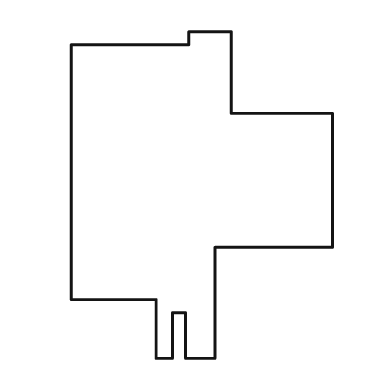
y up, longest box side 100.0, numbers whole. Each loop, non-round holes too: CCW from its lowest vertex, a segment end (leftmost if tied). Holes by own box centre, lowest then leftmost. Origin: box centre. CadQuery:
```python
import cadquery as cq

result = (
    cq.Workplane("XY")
    .moveTo(-14.0, -50.0)
    .lineTo(-9.0, -50.0)
    .lineTo(-9.0, -36.0)
    .lineTo(-5.0, -36.0)
    .lineTo(-5.0, -50.0)
    .lineTo(4.0, -50.0)
    .lineTo(4.0, -16.0)
    .lineTo(40.0, -16.0)
    .lineTo(40.0, 25.0)
    .lineTo(9.0, 25.0)
    .lineTo(9.0, 50.0)
    .lineTo(-4.0, 50.0)
    .lineTo(-4.0, 46.0)
    .lineTo(-40.0, 46.0)
    .lineTo(-40.0, -32.0)
    .lineTo(-14.0, -32.0)
    .close()
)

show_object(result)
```